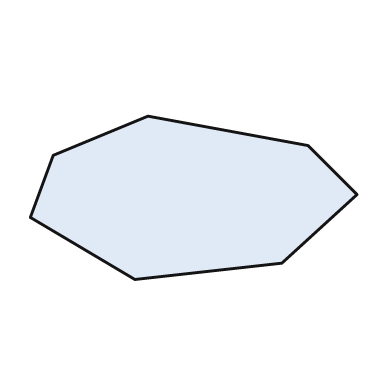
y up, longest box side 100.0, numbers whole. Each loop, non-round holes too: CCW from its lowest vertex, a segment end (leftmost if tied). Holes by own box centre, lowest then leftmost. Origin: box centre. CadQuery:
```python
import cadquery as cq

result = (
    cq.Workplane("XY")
    .moveTo(-18.0, -25.0)
    .lineTo(27.0, -20.0)
    .lineTo(50.0, 1.0)
    .lineTo(35.0, 16.0)
    .lineTo(-14.0, 25.0)
    .lineTo(-43.0, 13.0)
    .lineTo(-50.0, -6.0)
    .close()
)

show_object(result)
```